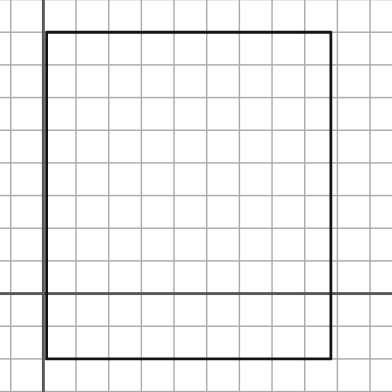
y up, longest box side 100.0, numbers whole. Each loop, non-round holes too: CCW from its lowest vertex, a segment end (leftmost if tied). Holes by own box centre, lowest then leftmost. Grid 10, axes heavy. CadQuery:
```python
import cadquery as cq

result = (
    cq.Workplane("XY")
    .moveTo(1.0, -20.0)
    .lineTo(88.0, -20.0)
    .lineTo(88.0, 80.0)
    .lineTo(1.0, 80.0)
    .close()
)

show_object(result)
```